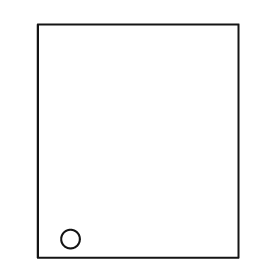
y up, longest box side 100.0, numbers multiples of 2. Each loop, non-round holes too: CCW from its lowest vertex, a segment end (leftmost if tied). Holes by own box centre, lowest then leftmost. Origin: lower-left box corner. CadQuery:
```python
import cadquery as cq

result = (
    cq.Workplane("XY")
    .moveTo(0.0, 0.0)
    .lineTo(86.0, 0.0)
    .lineTo(86.0, 100.0)
    .lineTo(0.0, 100.0)
    .close()
    .moveTo(14.0, 8.0)
    .circle(4.0)
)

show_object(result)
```